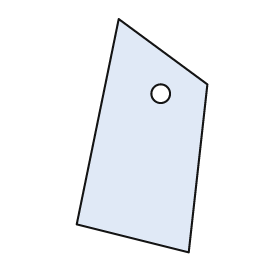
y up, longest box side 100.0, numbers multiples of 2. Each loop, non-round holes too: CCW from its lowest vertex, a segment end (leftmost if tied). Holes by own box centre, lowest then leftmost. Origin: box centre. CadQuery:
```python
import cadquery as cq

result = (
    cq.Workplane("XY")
    .moveTo(20.0, -50.0)
    .lineTo(28.0, 22.0)
    .lineTo(-10.0, 50.0)
    .lineTo(-28.0, -38.0)
    .close()
    .moveTo(8.0, 18.0)
    .circle(4.0)
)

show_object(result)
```